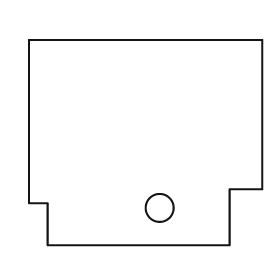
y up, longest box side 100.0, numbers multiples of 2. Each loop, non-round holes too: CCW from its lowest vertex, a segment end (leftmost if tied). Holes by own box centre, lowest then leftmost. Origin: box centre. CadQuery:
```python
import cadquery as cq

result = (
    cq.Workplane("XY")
    .moveTo(-42.0, -44.0)
    .lineTo(36.0, -44.0)
    .lineTo(36.0, -20.0)
    .lineTo(50.0, -20.0)
    .lineTo(50.0, 44.0)
    .lineTo(-50.0, 44.0)
    .lineTo(-50.0, -26.0)
    .lineTo(-42.0, -26.0)
    .close()
    .moveTo(6.0, -28.0)
    .circle(6.0)
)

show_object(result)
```